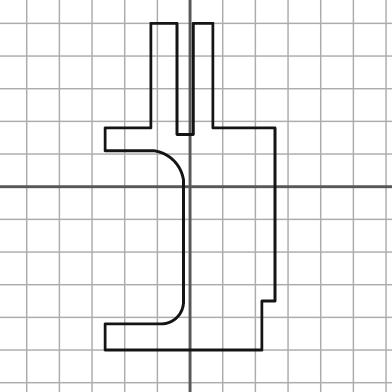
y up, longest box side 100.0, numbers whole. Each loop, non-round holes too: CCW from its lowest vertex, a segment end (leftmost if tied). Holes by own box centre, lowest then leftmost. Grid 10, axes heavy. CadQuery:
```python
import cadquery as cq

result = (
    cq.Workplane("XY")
    .moveTo(-26.0, -50.0)
    .lineTo(22.0, -50.0)
    .lineTo(22.0, -35.0)
    .lineTo(26.0, -35.0)
    .lineTo(26.0, 18.0)
    .lineTo(7.0, 18.0)
    .lineTo(7.0, 50.0)
    .lineTo(1.0, 50.0)
    .lineTo(1.0, 16.0)
    .lineTo(-4.0, 16.0)
    .lineTo(-4.0, 50.0)
    .lineTo(-12.0, 50.0)
    .lineTo(-12.0, 18.0)
    .lineTo(-26.0, 18.0)
    .lineTo(-26.0, 11.0)
    .lineTo(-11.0, 11.0)
    .threePointArc((-5.0, 8.0), (-2.0, 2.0))
    .lineTo(-2.0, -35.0)
    .threePointArc((-4.0, -40.0), (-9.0, -42.0))
    .lineTo(-26.0, -42.0)
    .close()
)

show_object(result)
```